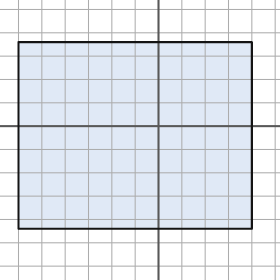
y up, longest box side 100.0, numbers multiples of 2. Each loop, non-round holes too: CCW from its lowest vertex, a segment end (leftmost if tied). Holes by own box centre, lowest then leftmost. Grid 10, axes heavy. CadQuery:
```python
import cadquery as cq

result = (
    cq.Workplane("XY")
    .moveTo(-60.0, -44.0)
    .lineTo(40.0, -44.0)
    .lineTo(40.0, 36.0)
    .lineTo(-60.0, 36.0)
    .close()
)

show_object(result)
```